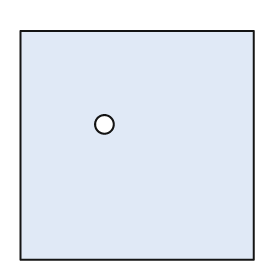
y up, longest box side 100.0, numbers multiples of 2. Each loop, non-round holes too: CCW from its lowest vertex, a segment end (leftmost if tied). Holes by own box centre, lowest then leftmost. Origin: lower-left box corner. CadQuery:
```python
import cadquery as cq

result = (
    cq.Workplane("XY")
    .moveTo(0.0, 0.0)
    .lineTo(100.0, 0.0)
    .lineTo(100.0, 98.0)
    .lineTo(0.0, 98.0)
    .close()
    .moveTo(36.0, 58.0)
    .circle(4.0)
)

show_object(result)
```